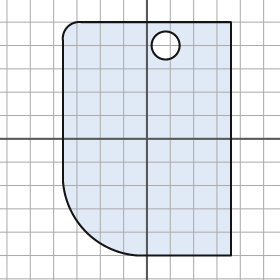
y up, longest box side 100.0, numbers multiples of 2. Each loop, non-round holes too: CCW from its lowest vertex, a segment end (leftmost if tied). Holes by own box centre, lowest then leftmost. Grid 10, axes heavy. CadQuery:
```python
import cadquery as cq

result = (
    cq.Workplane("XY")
    .moveTo(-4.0, -50.0)
    .lineTo(36.0, -50.0)
    .lineTo(36.0, 50.0)
    .lineTo(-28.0, 50.0)
    .threePointArc((-34.0, 48.0), (-36.0, 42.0))
    .lineTo(-36.0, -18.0)
    .threePointArc((-26.0, -40.0), (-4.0, -50.0))
    .close()
    .moveTo(8.0, 40.0)
    .circle(6.0)
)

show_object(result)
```